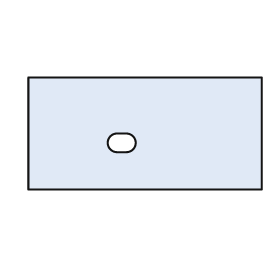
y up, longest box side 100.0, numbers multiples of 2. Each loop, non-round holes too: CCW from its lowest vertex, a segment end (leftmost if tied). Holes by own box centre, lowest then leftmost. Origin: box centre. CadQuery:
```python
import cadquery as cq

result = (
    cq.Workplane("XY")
    .moveTo(-50.0, -24.0)
    .lineTo(50.0, -24.0)
    .lineTo(50.0, 24.0)
    .lineTo(-50.0, 24.0)
    .close()
    .moveTo(-12.0, -8.0)
    .lineTo(-8.0, -8.0)
    .threePointArc((-4.0, -4.0), (-8.0, 0.0))
    .lineTo(-12.0, 0.0)
    .threePointArc((-16.0, -4.0), (-12.0, -8.0))
    .close()
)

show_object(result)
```